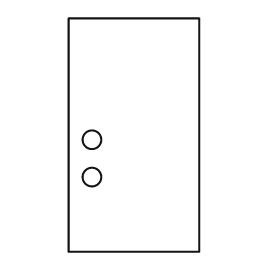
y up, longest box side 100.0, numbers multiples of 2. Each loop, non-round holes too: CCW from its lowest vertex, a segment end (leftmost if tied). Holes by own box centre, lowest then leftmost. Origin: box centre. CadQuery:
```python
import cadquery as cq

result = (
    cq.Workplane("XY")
    .moveTo(-28.0, -50.0)
    .lineTo(28.0, -50.0)
    .lineTo(28.0, 50.0)
    .lineTo(-28.0, 50.0)
    .close()
    .moveTo(-18.0, -18.0)
    .circle(4.0)
    .moveTo(-18.0, -2.0)
    .circle(4.0)
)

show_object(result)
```